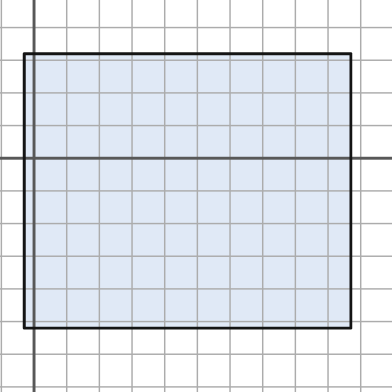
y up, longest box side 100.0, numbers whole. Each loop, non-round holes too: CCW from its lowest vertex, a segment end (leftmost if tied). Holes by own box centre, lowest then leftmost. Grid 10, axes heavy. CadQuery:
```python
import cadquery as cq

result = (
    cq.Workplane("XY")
    .moveTo(-3.0, -52.0)
    .lineTo(97.0, -52.0)
    .lineTo(97.0, 32.0)
    .lineTo(-3.0, 32.0)
    .close()
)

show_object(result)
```